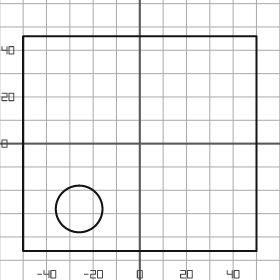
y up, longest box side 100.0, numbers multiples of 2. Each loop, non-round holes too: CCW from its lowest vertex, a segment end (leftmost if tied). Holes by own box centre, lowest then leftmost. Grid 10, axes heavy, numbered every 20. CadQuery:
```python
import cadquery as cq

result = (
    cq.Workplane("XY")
    .moveTo(-50.0, -46.0)
    .lineTo(50.0, -46.0)
    .lineTo(50.0, 46.0)
    .lineTo(-50.0, 46.0)
    .close()
    .moveTo(-26.0, -28.0)
    .circle(10.0)
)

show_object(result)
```